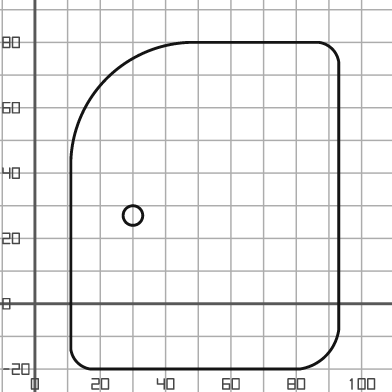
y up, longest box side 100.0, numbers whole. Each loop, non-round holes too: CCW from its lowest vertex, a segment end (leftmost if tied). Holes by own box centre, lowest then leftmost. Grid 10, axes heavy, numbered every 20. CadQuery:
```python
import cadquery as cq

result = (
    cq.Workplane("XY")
    .moveTo(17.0, -20.0)
    .lineTo(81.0, -20.0)
    .threePointArc((89.0, -16.0), (93.0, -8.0))
    .lineTo(93.0, 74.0)
    .threePointArc((91.0, 78.0), (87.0, 80.0))
    .lineTo(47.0, 80.0)
    .threePointArc((22.0, 69.0), (11.0, 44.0))
    .lineTo(11.0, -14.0)
    .threePointArc((13.0, -18.0), (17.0, -20.0))
    .close()
    .moveTo(30.0, 27.0)
    .circle(3.0)
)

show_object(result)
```